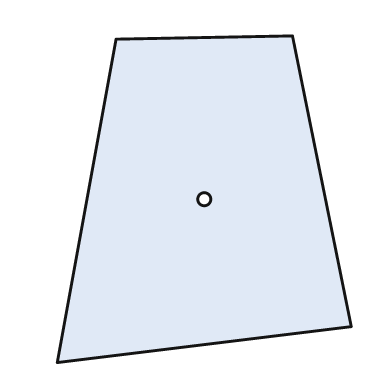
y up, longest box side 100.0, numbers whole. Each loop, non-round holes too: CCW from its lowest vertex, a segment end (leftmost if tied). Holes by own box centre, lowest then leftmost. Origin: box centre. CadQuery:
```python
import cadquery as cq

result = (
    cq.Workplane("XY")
    .moveTo(-45.0, -50.0)
    .lineTo(45.0, -39.0)
    .lineTo(27.0, 50.0)
    .lineTo(-27.0, 49.0)
    .close()
    .moveTo(0.0, 0.0)
    .circle(2.0)
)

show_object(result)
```